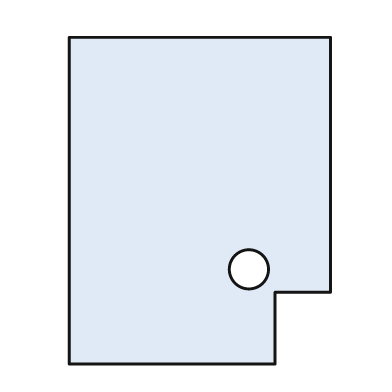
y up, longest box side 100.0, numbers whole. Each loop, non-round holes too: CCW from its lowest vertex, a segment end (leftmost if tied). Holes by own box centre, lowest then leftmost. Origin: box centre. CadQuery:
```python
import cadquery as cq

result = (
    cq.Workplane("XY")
    .moveTo(-40.0, -50.0)
    .lineTo(23.0, -50.0)
    .lineTo(23.0, -28.0)
    .lineTo(40.0, -28.0)
    .lineTo(40.0, 50.0)
    .lineTo(-40.0, 50.0)
    .close()
    .moveTo(15.0, -21.0)
    .circle(6.0)
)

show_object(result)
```